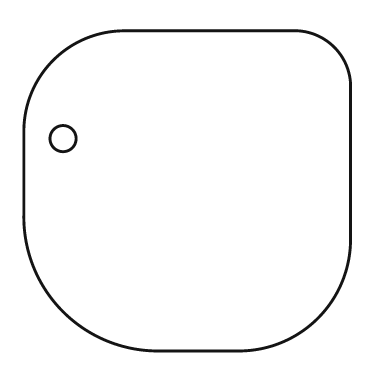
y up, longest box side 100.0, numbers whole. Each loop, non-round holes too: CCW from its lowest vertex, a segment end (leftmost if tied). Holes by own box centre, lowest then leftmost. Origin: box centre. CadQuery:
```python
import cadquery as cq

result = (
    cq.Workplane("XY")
    .moveTo(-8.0, -49.0)
    .lineTo(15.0, -49.0)
    .threePointArc((40.0, -39.0), (50.0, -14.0))
    .lineTo(50.0, 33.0)
    .threePointArc((45.0, 44.0), (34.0, 49.0))
    .lineTo(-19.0, 49.0)
    .threePointArc((-41.0, 40.0), (-50.0, 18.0))
    .lineTo(-50.0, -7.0)
    .threePointArc((-38.0, -37.0), (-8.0, -49.0))
    .close()
    .moveTo(-38.0, 16.0)
    .circle(4.0)
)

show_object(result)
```